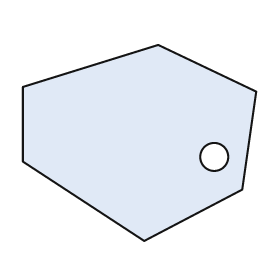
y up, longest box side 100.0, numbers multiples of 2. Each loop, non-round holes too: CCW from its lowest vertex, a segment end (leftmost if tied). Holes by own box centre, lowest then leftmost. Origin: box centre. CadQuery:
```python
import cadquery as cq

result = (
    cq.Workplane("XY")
    .moveTo(2.0, -42.0)
    .lineTo(44.0, -20.0)
    .lineTo(50.0, 22.0)
    .lineTo(8.0, 42.0)
    .lineTo(-50.0, 24.0)
    .lineTo(-50.0, -8.0)
    .close()
    .moveTo(32.0, -6.0)
    .circle(6.0)
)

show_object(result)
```